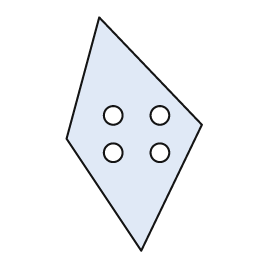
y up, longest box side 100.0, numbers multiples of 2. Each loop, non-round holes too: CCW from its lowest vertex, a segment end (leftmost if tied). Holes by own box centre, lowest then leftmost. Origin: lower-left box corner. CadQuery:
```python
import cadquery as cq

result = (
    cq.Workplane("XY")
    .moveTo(32.0, 0.0)
    .lineTo(58.0, 54.0)
    .lineTo(14.0, 100.0)
    .lineTo(0.0, 48.0)
    .close()
    .moveTo(20.0, 42.0)
    .circle(4.0)
    .moveTo(40.0, 42.0)
    .circle(4.0)
    .moveTo(20.0, 58.0)
    .circle(4.0)
    .moveTo(40.0, 58.0)
    .circle(4.0)
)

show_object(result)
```